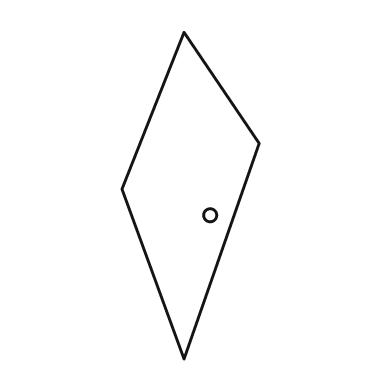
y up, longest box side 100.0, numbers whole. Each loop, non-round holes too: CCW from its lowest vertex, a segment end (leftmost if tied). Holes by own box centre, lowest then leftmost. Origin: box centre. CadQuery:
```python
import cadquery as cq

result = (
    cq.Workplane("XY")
    .moveTo(-2.0, -50.0)
    .lineTo(21.0, 16.0)
    .lineTo(-2.0, 50.0)
    .lineTo(-21.0, 2.0)
    .close()
    .moveTo(6.0, -6.0)
    .circle(2.0)
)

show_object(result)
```